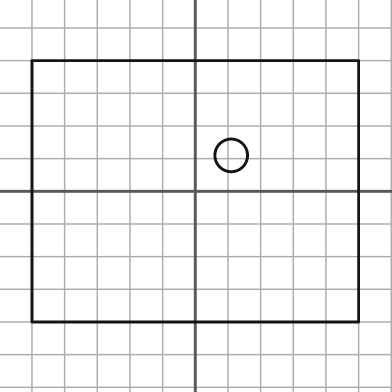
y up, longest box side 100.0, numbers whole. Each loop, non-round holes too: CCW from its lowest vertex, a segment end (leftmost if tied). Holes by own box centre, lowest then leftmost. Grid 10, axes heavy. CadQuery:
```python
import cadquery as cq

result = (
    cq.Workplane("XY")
    .moveTo(-50.0, -40.0)
    .lineTo(50.0, -40.0)
    .lineTo(50.0, 40.0)
    .lineTo(-50.0, 40.0)
    .close()
    .moveTo(11.0, 11.0)
    .circle(5.0)
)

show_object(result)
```